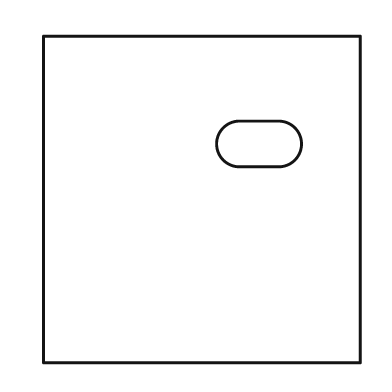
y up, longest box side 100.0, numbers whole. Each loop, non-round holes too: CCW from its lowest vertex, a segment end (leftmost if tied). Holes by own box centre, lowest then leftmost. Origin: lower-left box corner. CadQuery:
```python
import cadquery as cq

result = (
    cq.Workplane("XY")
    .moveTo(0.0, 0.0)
    .lineTo(97.0, 0.0)
    .lineTo(97.0, 100.0)
    .lineTo(0.0, 100.0)
    .close()
    .moveTo(60.0, 60.0)
    .lineTo(72.0, 60.0)
    .threePointArc((79.0, 67.0), (72.0, 74.0))
    .lineTo(60.0, 74.0)
    .threePointArc((53.0, 67.0), (60.0, 60.0))
    .close()
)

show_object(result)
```